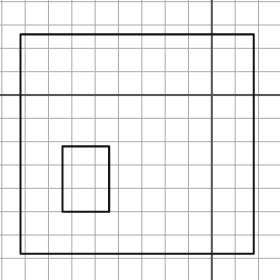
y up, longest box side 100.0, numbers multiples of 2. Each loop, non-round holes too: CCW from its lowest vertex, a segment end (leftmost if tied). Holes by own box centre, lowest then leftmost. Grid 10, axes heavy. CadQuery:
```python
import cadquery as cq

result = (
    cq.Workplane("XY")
    .moveTo(-82.0, -68.0)
    .lineTo(18.0, -68.0)
    .lineTo(18.0, 26.0)
    .lineTo(-82.0, 26.0)
    .close()
    .moveTo(-64.0, -50.0)
    .lineTo(-44.0, -50.0)
    .lineTo(-44.0, -22.0)
    .lineTo(-64.0, -22.0)
    .close()
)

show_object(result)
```